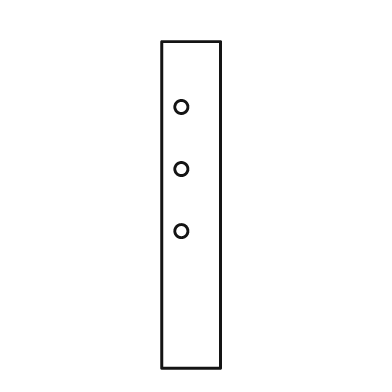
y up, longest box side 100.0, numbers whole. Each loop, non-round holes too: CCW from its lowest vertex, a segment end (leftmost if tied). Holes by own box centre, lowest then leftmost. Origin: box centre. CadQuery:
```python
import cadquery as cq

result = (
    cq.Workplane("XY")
    .moveTo(-9.0, -50.0)
    .lineTo(9.0, -50.0)
    .lineTo(9.0, 50.0)
    .lineTo(-9.0, 50.0)
    .close()
    .moveTo(-3.0, -8.0)
    .circle(2.0)
    .moveTo(-3.0, 11.0)
    .circle(2.0)
    .moveTo(-3.0, 30.0)
    .circle(2.0)
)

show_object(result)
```